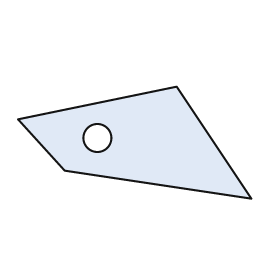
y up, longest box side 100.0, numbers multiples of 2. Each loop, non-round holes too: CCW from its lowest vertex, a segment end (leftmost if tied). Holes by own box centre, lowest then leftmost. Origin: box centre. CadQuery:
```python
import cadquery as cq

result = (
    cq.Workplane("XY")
    .moveTo(50.0, -24.0)
    .lineTo(18.0, 24.0)
    .lineTo(-50.0, 10.0)
    .lineTo(-30.0, -12.0)
    .close()
    .moveTo(-16.0, 2.0)
    .circle(6.0)
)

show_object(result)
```